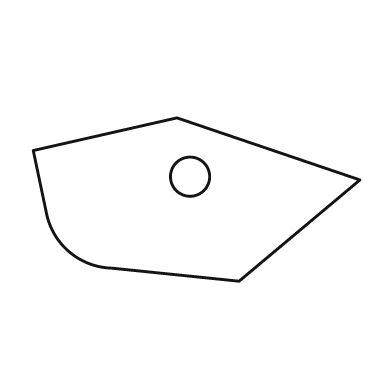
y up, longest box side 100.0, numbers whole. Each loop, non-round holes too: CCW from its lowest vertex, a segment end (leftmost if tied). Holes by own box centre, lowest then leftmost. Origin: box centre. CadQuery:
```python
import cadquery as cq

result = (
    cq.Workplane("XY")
    .moveTo(13.0, -25.0)
    .lineTo(50.0, 6.0)
    .lineTo(-6.0, 25.0)
    .lineTo(-50.0, 15.0)
    .lineTo(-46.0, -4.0)
    .threePointArc((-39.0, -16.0), (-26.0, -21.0))
    .close()
    .moveTo(-2.0, 7.0)
    .circle(6.0)
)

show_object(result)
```